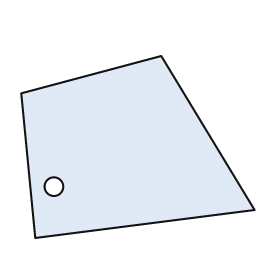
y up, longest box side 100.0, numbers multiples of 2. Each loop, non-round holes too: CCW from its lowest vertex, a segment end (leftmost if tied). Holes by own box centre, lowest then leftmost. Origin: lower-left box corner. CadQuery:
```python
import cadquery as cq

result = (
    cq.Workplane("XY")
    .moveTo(6.0, 0.0)
    .lineTo(100.0, 12.0)
    .lineTo(60.0, 78.0)
    .lineTo(0.0, 62.0)
    .close()
    .moveTo(14.0, 22.0)
    .circle(4.0)
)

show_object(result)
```